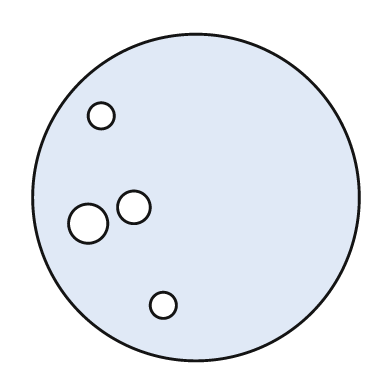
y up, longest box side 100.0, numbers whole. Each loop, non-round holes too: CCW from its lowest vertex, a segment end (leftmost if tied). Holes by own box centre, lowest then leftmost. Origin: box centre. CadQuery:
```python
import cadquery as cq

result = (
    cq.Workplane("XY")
    .moveTo(0.0, 0.0)
    .circle(50.0)
    .moveTo(-10.0, -33.0)
    .circle(4.0)
    .moveTo(-33.0, -8.0)
    .circle(6.0)
    .moveTo(-19.0, -3.0)
    .circle(5.0)
    .moveTo(-29.0, 25.0)
    .circle(4.0)
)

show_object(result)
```